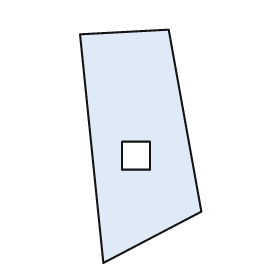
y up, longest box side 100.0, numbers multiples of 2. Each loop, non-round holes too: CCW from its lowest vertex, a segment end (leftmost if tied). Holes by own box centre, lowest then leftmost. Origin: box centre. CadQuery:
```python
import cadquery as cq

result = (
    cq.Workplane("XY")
    .moveTo(-16.0, -50.0)
    .lineTo(26.0, -28.0)
    .lineTo(12.0, 50.0)
    .lineTo(-26.0, 48.0)
    .close()
    .moveTo(-8.0, -10.0)
    .lineTo(4.0, -10.0)
    .lineTo(4.0, 2.0)
    .lineTo(-8.0, 2.0)
    .close()
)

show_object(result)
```